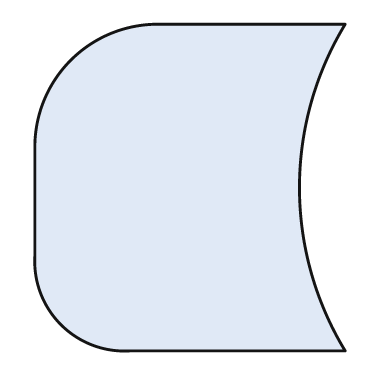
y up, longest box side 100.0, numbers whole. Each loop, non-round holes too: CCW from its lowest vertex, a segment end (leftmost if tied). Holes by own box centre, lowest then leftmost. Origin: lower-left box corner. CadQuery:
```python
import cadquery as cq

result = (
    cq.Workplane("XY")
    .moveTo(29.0, 0.0)
    .lineTo(95.0, 0.0)
    .threePointArc((81.0, 50.0), (95.0, 100.0))
    .lineTo(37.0, 100.0)
    .threePointArc((11.0, 89.0), (0.0, 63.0))
    .lineTo(0.0, 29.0)
    .threePointArc((8.0, 8.0), (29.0, 0.0))
    .close()
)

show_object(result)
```